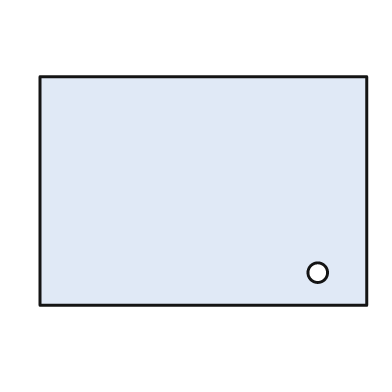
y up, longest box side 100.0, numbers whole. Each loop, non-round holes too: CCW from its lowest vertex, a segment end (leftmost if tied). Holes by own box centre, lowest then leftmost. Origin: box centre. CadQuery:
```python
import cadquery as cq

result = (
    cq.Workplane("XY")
    .moveTo(-50.0, -35.0)
    .lineTo(50.0, -35.0)
    .lineTo(50.0, 35.0)
    .lineTo(-50.0, 35.0)
    .close()
    .moveTo(35.0, -25.0)
    .circle(3.0)
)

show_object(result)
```